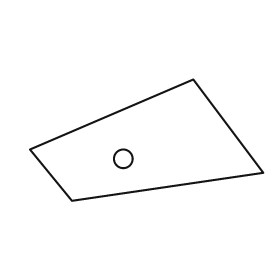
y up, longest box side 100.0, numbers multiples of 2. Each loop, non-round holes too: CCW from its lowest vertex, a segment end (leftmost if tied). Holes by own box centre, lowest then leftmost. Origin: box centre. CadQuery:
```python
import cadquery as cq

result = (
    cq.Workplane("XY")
    .moveTo(-32.0, -26.0)
    .lineTo(50.0, -14.0)
    .lineTo(20.0, 26.0)
    .lineTo(-50.0, -4.0)
    .close()
    .moveTo(-10.0, -8.0)
    .circle(4.0)
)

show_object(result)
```